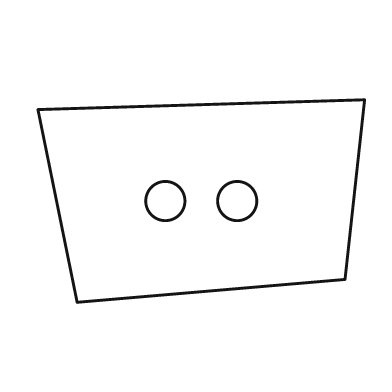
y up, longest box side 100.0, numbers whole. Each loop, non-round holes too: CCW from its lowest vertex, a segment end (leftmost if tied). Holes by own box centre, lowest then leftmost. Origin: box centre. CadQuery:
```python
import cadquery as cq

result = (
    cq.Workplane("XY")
    .moveTo(-38.0, -31.0)
    .lineTo(44.0, -24.0)
    .lineTo(50.0, 31.0)
    .lineTo(-50.0, 28.0)
    .close()
    .moveTo(-11.0, 0.0)
    .circle(6.0)
    .moveTo(11.0, 0.0)
    .circle(6.0)
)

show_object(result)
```